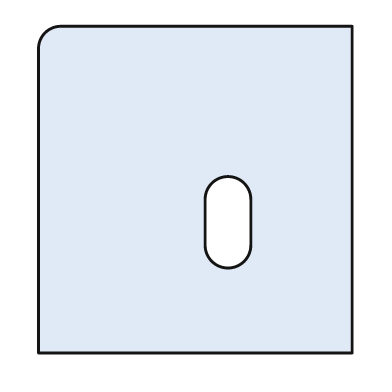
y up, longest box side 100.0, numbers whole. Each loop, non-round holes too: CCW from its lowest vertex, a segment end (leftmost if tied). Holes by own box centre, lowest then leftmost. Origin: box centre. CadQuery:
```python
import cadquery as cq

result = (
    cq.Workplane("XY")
    .moveTo(-48.0, -50.0)
    .lineTo(48.0, -50.0)
    .lineTo(48.0, 50.0)
    .lineTo(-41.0, 50.0)
    .threePointArc((-46.0, 48.0), (-48.0, 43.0))
    .close()
    .moveTo(3.0, -17.0)
    .threePointArc((10.0, -24.0), (17.0, -17.0))
    .lineTo(17.0, -3.0)
    .threePointArc((10.0, 4.0), (3.0, -3.0))
    .close()
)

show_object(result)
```